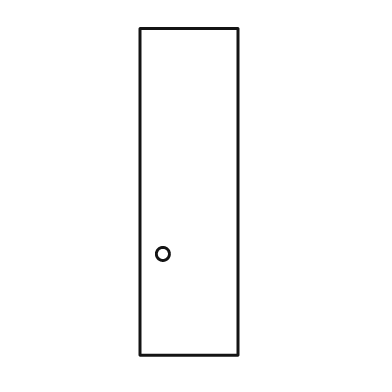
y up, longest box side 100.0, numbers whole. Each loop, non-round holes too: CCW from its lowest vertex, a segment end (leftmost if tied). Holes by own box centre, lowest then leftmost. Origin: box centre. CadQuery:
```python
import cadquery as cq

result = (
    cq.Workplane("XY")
    .moveTo(-15.0, -50.0)
    .lineTo(15.0, -50.0)
    .lineTo(15.0, 50.0)
    .lineTo(-15.0, 50.0)
    .close()
    .moveTo(-8.0, -19.0)
    .circle(2.0)
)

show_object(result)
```